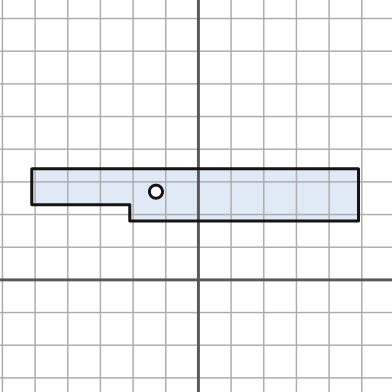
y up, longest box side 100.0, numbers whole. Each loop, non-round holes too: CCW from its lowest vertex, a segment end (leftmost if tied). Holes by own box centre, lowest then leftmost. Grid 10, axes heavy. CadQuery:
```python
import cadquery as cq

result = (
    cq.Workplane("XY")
    .moveTo(-21.0, 18.0)
    .lineTo(49.0, 18.0)
    .lineTo(49.0, 34.0)
    .lineTo(-51.0, 34.0)
    .lineTo(-51.0, 23.0)
    .lineTo(-21.0, 23.0)
    .close()
    .moveTo(-13.0, 27.0)
    .circle(2.0)
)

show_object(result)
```